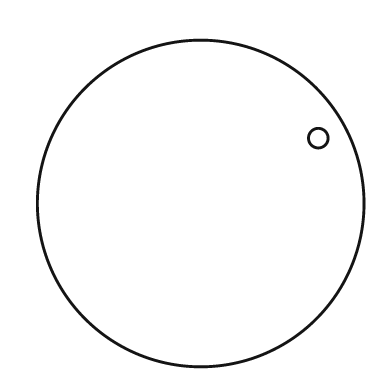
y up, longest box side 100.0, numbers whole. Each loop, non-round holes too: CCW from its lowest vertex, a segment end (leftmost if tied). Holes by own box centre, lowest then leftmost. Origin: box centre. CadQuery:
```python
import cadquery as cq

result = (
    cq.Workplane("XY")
    .moveTo(0.0, 0.0)
    .circle(50.0)
    .moveTo(36.0, 20.0)
    .circle(3.0)
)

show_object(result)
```